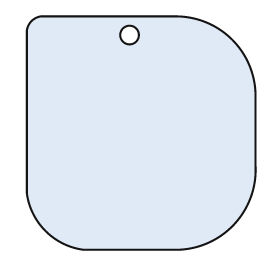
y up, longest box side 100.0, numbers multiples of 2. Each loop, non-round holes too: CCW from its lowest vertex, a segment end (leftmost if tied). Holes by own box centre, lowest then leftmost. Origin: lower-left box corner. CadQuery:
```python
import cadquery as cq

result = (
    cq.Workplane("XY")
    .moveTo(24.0, 0.0)
    .lineTo(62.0, 0.0)
    .threePointArc((88.0, 10.0), (98.0, 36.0))
    .lineTo(98.0, 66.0)
    .threePointArc((88.0, 90.0), (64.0, 100.0))
    .lineTo(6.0, 100.0)
    .threePointArc((2.0, 98.0), (0.0, 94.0))
    .lineTo(0.0, 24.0)
    .threePointArc((8.0, 8.0), (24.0, 0.0))
    .close()
    .moveTo(44.0, 92.0)
    .circle(4.0)
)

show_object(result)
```